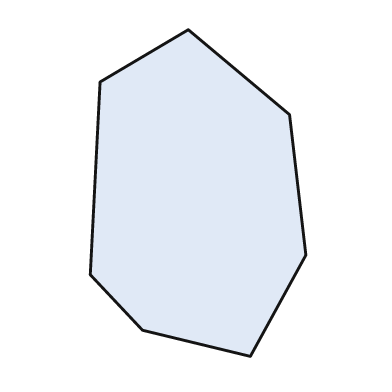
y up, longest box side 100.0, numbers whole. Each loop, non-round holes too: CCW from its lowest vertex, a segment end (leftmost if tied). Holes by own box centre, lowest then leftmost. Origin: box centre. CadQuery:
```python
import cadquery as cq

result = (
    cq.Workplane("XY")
    .moveTo(16.0, -50.0)
    .lineTo(33.0, -19.0)
    .lineTo(28.0, 24.0)
    .lineTo(-3.0, 50.0)
    .lineTo(-30.0, 34.0)
    .lineTo(-33.0, -25.0)
    .lineTo(-17.0, -42.0)
    .close()
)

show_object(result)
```